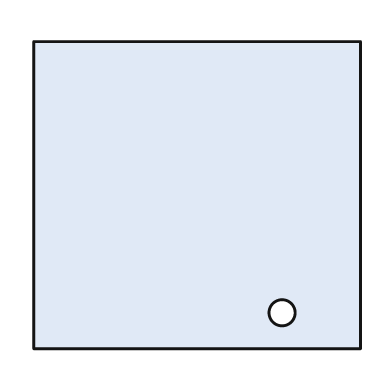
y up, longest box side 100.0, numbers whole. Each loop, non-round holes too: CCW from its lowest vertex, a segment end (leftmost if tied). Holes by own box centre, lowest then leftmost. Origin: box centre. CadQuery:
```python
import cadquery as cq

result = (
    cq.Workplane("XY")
    .moveTo(-50.0, -47.0)
    .lineTo(50.0, -47.0)
    .lineTo(50.0, 47.0)
    .lineTo(-50.0, 47.0)
    .close()
    .moveTo(26.0, -36.0)
    .circle(4.0)
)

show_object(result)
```